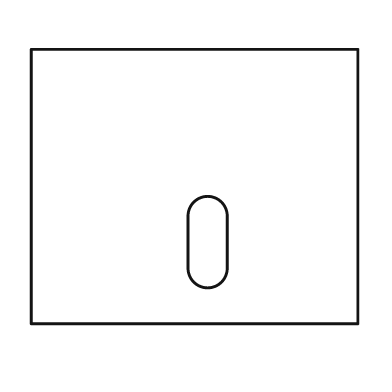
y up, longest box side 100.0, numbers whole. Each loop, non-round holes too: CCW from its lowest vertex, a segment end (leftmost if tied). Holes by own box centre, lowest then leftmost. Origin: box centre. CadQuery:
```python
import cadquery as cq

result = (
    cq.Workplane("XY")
    .moveTo(-50.0, -42.0)
    .lineTo(50.0, -42.0)
    .lineTo(50.0, 42.0)
    .lineTo(-50.0, 42.0)
    .close()
    .moveTo(-2.0, -25.0)
    .threePointArc((4.0, -31.0), (10.0, -25.0))
    .lineTo(10.0, -9.0)
    .threePointArc((4.0, -3.0), (-2.0, -9.0))
    .close()
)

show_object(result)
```